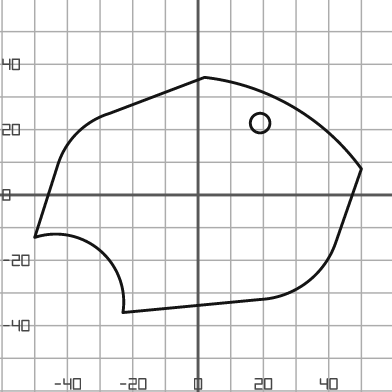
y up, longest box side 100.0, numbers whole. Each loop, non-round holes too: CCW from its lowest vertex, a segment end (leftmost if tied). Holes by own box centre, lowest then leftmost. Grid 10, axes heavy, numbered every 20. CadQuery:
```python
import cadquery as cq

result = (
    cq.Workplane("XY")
    .moveTo(-23.0, -36.0)
    .lineTo(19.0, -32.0)
    .threePointArc((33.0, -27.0), (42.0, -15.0))
    .lineTo(50.0, 8.0)
    .threePointArc((29.0, 27.0), (2.0, 36.0))
    .lineTo(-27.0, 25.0)
    .threePointArc((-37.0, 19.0), (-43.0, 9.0))
    .lineTo(-50.0, -13.0)
    .threePointArc((-30.0, -17.0), (-23.0, -36.0))
    .close()
    .moveTo(19.0, 22.0)
    .circle(3.0)
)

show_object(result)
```